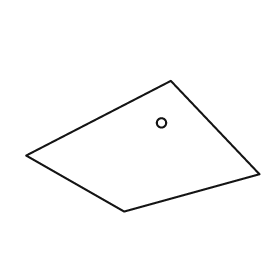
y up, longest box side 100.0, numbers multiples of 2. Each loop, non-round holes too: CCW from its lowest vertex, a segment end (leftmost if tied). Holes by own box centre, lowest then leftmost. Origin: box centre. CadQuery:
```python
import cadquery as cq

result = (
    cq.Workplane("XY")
    .moveTo(-8.0, -28.0)
    .lineTo(50.0, -12.0)
    .lineTo(12.0, 28.0)
    .lineTo(-50.0, -4.0)
    .close()
    .moveTo(8.0, 10.0)
    .circle(2.0)
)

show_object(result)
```